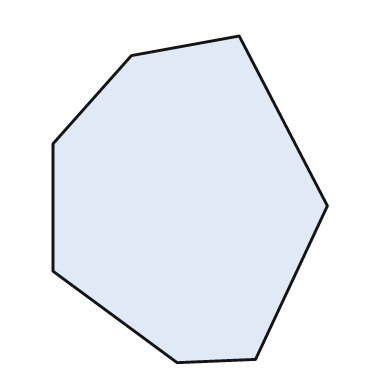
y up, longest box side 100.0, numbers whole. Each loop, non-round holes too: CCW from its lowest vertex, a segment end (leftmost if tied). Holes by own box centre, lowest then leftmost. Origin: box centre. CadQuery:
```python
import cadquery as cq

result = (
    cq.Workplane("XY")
    .moveTo(-4.0, -50.0)
    .lineTo(20.0, -49.0)
    .lineTo(42.0, -2.0)
    .lineTo(15.0, 50.0)
    .lineTo(-18.0, 44.0)
    .lineTo(-42.0, 17.0)
    .lineTo(-42.0, -22.0)
    .close()
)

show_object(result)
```